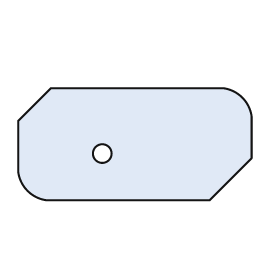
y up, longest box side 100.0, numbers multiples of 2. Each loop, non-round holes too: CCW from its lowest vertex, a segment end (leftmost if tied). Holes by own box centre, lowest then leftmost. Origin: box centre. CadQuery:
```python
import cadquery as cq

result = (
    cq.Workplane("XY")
    .moveTo(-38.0, -24.0)
    .lineTo(32.0, -24.0)
    .lineTo(50.0, -6.0)
    .lineTo(50.0, 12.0)
    .threePointArc((46.0, 20.0), (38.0, 24.0))
    .lineTo(-36.0, 24.0)
    .lineTo(-50.0, 10.0)
    .lineTo(-50.0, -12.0)
    .threePointArc((-46.0, -20.0), (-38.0, -24.0))
    .close()
    .moveTo(-14.0, -4.0)
    .circle(4.0)
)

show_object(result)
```